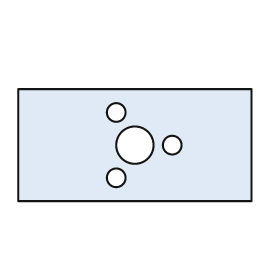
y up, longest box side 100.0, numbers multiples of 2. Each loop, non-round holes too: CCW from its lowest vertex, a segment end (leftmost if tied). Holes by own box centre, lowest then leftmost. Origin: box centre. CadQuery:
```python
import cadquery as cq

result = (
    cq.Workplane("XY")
    .moveTo(-50.0, -24.0)
    .lineTo(50.0, -24.0)
    .lineTo(50.0, 24.0)
    .lineTo(-50.0, 24.0)
    .close()
    .moveTo(-8.0, -14.0)
    .circle(4.0)
    .moveTo(0.0, 0.0)
    .circle(8.0)
    .moveTo(16.0, 0.0)
    .circle(4.0)
    .moveTo(-8.0, 14.0)
    .circle(4.0)
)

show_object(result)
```